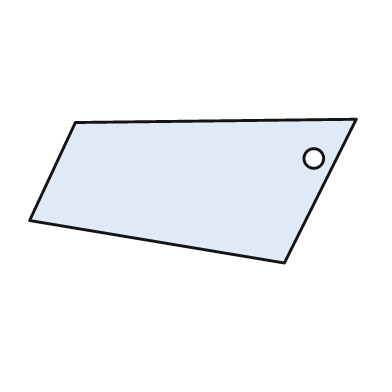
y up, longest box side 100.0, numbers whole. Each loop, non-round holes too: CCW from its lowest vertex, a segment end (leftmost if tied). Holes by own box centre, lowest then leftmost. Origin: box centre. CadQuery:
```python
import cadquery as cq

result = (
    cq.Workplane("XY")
    .moveTo(28.0, -22.0)
    .lineTo(50.0, 22.0)
    .lineTo(-36.0, 21.0)
    .lineTo(-50.0, -9.0)
    .close()
    .moveTo(37.0, 10.0)
    .circle(3.0)
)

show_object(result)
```